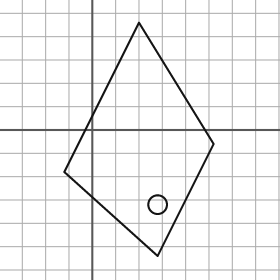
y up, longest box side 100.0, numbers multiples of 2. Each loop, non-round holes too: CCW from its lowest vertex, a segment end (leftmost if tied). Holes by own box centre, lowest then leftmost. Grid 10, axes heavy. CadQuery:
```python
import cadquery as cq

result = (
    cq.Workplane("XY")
    .moveTo(28.0, -54.0)
    .lineTo(52.0, -6.0)
    .lineTo(20.0, 46.0)
    .lineTo(-12.0, -18.0)
    .close()
    .moveTo(28.0, -32.0)
    .circle(4.0)
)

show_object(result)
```